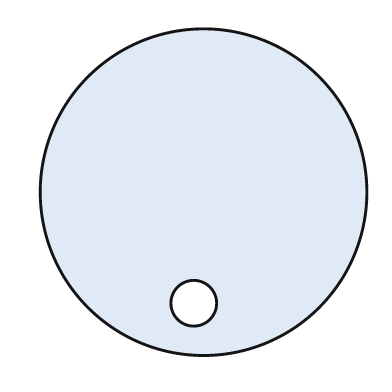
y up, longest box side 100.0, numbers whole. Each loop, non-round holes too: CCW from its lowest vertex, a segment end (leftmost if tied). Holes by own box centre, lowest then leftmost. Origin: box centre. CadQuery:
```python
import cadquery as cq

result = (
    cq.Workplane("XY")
    .moveTo(0.0, 0.0)
    .circle(50.0)
    .moveTo(-3.0, -34.0)
    .circle(7.0)
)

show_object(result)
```